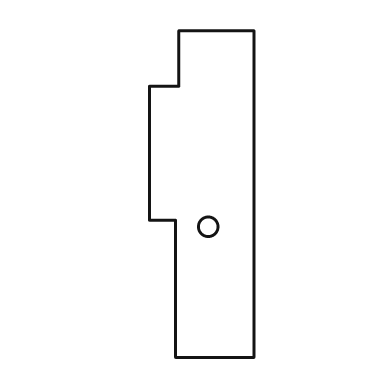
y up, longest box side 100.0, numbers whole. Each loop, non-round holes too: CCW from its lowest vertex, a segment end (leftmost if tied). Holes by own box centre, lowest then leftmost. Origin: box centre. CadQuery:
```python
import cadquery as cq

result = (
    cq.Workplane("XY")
    .moveTo(-8.0, -50.0)
    .lineTo(16.0, -50.0)
    .lineTo(16.0, 50.0)
    .lineTo(-7.0, 50.0)
    .lineTo(-7.0, 33.0)
    .lineTo(-16.0, 33.0)
    .lineTo(-16.0, -8.0)
    .lineTo(-8.0, -8.0)
    .close()
    .moveTo(2.0, -10.0)
    .circle(3.0)
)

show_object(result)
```